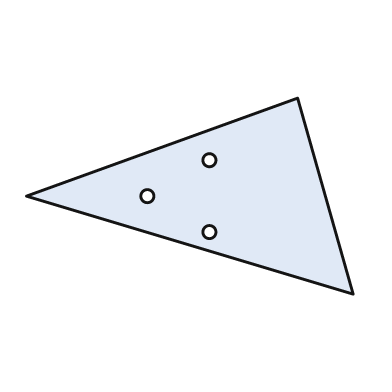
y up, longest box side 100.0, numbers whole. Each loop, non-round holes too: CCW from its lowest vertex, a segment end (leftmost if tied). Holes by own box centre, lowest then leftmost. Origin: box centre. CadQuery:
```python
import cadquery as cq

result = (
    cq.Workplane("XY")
    .moveTo(50.0, -30.0)
    .lineTo(33.0, 30.0)
    .lineTo(-50.0, 0.0)
    .close()
    .moveTo(6.0, -11.0)
    .circle(2.0)
    .moveTo(-13.0, 0.0)
    .circle(2.0)
    .moveTo(6.0, 11.0)
    .circle(2.0)
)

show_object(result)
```